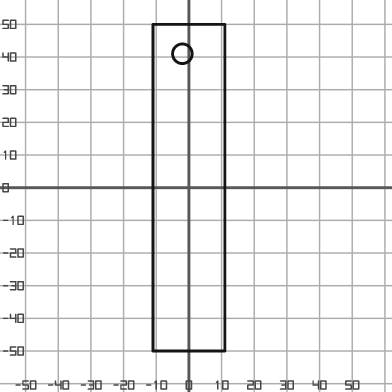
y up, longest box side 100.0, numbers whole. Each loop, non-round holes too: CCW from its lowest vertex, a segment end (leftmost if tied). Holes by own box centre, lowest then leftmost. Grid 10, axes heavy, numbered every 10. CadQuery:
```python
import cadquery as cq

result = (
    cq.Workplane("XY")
    .moveTo(-11.0, -50.0)
    .lineTo(11.0, -50.0)
    .lineTo(11.0, 50.0)
    .lineTo(-11.0, 50.0)
    .close()
    .moveTo(-2.0, 41.0)
    .circle(3.0)
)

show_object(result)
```